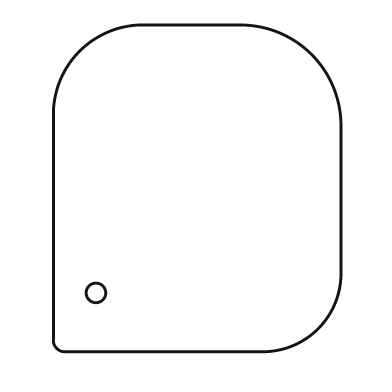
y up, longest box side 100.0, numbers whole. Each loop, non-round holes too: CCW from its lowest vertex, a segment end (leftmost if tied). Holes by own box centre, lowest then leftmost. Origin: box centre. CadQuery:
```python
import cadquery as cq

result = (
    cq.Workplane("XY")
    .moveTo(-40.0, -50.0)
    .lineTo(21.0, -50.0)
    .threePointArc((37.0, -43.0), (44.0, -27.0))
    .lineTo(44.0, 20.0)
    .threePointArc((35.0, 41.0), (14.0, 50.0))
    .lineTo(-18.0, 50.0)
    .threePointArc((-36.0, 42.0), (-44.0, 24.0))
    .lineTo(-44.0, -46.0)
    .threePointArc((-43.0, -49.0), (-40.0, -50.0))
    .close()
    .moveTo(-31.0, -32.0)
    .circle(3.0)
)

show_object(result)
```